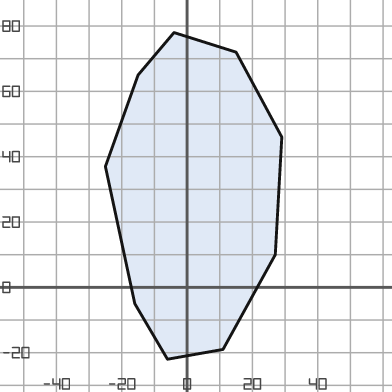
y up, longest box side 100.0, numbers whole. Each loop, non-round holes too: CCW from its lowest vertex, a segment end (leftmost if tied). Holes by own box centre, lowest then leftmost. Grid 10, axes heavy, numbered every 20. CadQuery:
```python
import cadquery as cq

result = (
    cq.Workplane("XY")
    .moveTo(-6.0, -22.0)
    .lineTo(11.0, -19.0)
    .lineTo(27.0, 10.0)
    .lineTo(29.0, 46.0)
    .lineTo(15.0, 72.0)
    .lineTo(-4.0, 78.0)
    .lineTo(-15.0, 65.0)
    .lineTo(-25.0, 37.0)
    .lineTo(-16.0, -5.0)
    .close()
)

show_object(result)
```